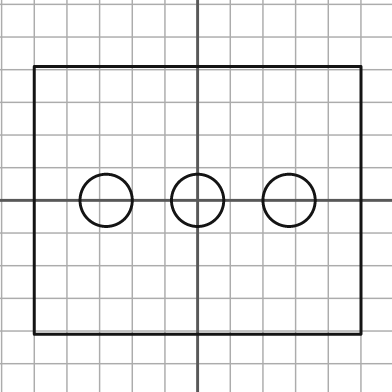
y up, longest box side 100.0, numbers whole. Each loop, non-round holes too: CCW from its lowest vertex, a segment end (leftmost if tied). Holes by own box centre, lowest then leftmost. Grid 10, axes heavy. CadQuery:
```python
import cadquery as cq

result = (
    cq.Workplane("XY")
    .moveTo(-50.0, -41.0)
    .lineTo(50.0, -41.0)
    .lineTo(50.0, 41.0)
    .lineTo(-50.0, 41.0)
    .close()
    .moveTo(-28.0, 0.0)
    .circle(8.0)
    .moveTo(0.0, 0.0)
    .circle(8.0)
    .moveTo(28.0, 0.0)
    .circle(8.0)
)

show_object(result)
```